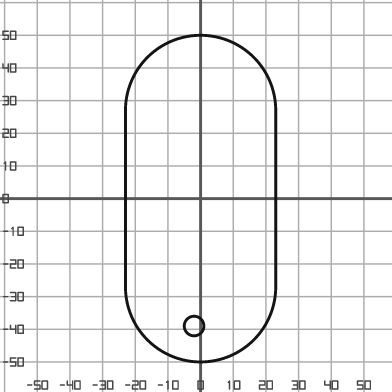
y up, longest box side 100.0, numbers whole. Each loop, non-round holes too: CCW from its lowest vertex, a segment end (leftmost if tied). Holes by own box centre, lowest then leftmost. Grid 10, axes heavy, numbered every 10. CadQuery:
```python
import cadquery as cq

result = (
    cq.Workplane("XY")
    .moveTo(-23.0, -27.0)
    .threePointArc((0.0, -50.0), (23.0, -27.0))
    .lineTo(23.0, 27.0)
    .threePointArc((0.0, 50.0), (-23.0, 27.0))
    .close()
    .moveTo(-2.0, -39.0)
    .circle(3.0)
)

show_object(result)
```